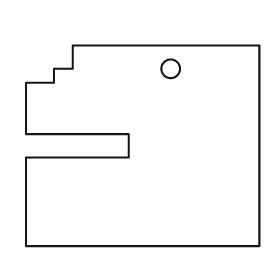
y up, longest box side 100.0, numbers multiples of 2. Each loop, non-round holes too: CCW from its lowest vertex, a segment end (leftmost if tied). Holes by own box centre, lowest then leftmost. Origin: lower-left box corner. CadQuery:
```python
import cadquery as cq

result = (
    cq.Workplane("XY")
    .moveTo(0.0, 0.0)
    .lineTo(100.0, 0.0)
    .lineTo(100.0, 86.0)
    .lineTo(20.0, 86.0)
    .lineTo(20.0, 76.0)
    .lineTo(12.0, 76.0)
    .lineTo(12.0, 70.0)
    .lineTo(0.0, 70.0)
    .lineTo(0.0, 48.0)
    .lineTo(44.0, 48.0)
    .lineTo(44.0, 38.0)
    .lineTo(0.0, 38.0)
    .close()
    .moveTo(62.0, 76.0)
    .circle(4.0)
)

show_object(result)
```